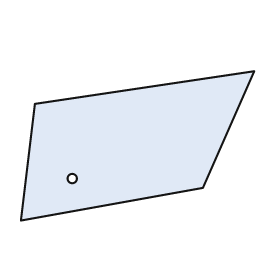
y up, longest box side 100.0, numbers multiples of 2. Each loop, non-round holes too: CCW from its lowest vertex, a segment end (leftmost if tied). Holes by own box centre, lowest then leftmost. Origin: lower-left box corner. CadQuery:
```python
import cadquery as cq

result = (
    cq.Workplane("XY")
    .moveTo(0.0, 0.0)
    .lineTo(78.0, 14.0)
    .lineTo(100.0, 64.0)
    .lineTo(6.0, 50.0)
    .close()
    .moveTo(22.0, 18.0)
    .circle(2.0)
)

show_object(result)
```